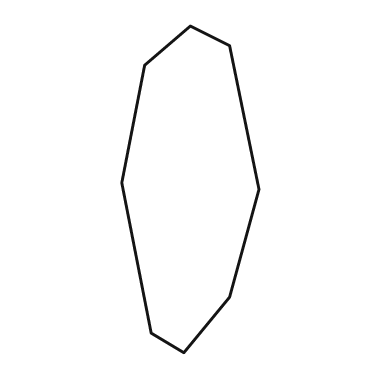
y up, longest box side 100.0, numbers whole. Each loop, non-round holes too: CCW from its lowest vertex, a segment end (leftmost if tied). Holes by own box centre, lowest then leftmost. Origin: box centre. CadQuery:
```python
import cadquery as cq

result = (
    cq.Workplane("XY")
    .moveTo(-2.0, -50.0)
    .lineTo(12.0, -33.0)
    .lineTo(21.0, 0.0)
    .lineTo(12.0, 44.0)
    .lineTo(0.0, 50.0)
    .lineTo(-14.0, 38.0)
    .lineTo(-21.0, 2.0)
    .lineTo(-12.0, -44.0)
    .close()
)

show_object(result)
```